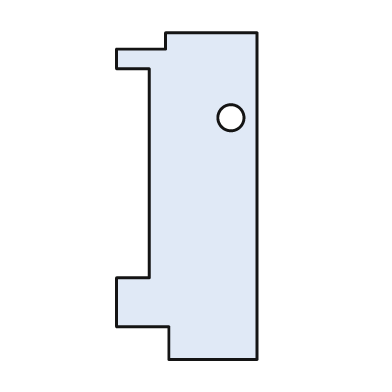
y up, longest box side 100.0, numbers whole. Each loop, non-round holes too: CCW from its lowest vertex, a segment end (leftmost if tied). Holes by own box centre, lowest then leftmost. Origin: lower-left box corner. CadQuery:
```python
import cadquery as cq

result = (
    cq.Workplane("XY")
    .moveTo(16.0, 0.0)
    .lineTo(43.0, 0.0)
    .lineTo(43.0, 100.0)
    .lineTo(15.0, 100.0)
    .lineTo(15.0, 95.0)
    .lineTo(0.0, 95.0)
    .lineTo(0.0, 89.0)
    .lineTo(10.0, 89.0)
    .lineTo(10.0, 25.0)
    .lineTo(0.0, 25.0)
    .lineTo(0.0, 10.0)
    .lineTo(16.0, 10.0)
    .close()
    .moveTo(35.0, 74.0)
    .circle(4.0)
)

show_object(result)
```